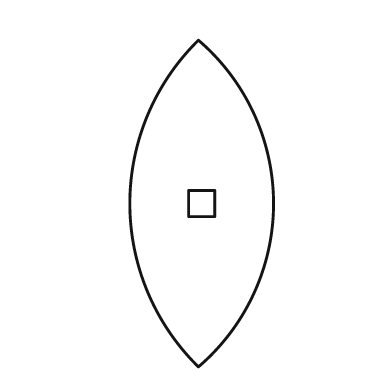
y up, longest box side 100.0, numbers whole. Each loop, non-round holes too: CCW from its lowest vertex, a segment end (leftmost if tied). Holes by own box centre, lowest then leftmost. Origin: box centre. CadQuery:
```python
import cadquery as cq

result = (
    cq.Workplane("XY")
    .moveTo(-1.0, -50.0)
    .threePointArc((22.0, 0.0), (-1.0, 50.0))
    .threePointArc((-22.0, 0.0), (-1.0, -50.0))
    .close()
    .moveTo(-4.0, -4.0)
    .lineTo(4.0, -4.0)
    .lineTo(4.0, 4.0)
    .lineTo(-4.0, 4.0)
    .close()
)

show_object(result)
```